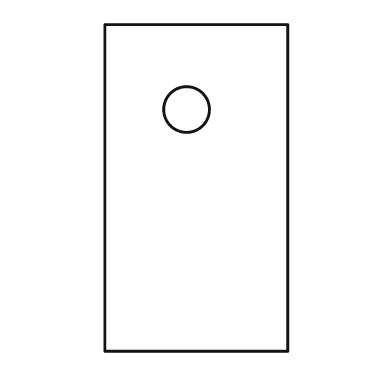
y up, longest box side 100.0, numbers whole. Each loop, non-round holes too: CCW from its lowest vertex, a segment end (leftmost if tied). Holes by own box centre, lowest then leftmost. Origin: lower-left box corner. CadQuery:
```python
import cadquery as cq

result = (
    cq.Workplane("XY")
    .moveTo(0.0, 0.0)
    .lineTo(56.0, 0.0)
    .lineTo(56.0, 100.0)
    .lineTo(0.0, 100.0)
    .close()
    .moveTo(25.0, 74.0)
    .circle(7.0)
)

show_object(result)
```